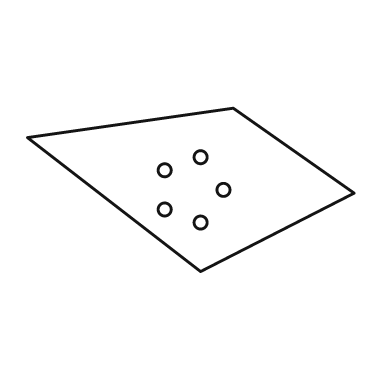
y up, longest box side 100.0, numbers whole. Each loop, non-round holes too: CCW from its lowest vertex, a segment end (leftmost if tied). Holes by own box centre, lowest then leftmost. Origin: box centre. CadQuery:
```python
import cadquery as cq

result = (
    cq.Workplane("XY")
    .moveTo(3.0, -25.0)
    .lineTo(50.0, -1.0)
    .lineTo(13.0, 25.0)
    .lineTo(-50.0, 16.0)
    .close()
    .moveTo(3.0, -10.0)
    .circle(2.0)
    .moveTo(-8.0, -6.0)
    .circle(2.0)
    .moveTo(10.0, 0.0)
    .circle(2.0)
    .moveTo(-8.0, 6.0)
    .circle(2.0)
    .moveTo(3.0, 10.0)
    .circle(2.0)
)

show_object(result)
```